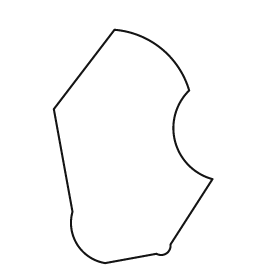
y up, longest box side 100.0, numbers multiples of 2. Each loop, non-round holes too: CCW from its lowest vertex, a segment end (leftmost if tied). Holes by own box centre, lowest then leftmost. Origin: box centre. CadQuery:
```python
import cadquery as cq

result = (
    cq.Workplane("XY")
    .moveTo(-12.0, -50.0)
    .lineTo(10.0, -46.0)
    .threePointArc((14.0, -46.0), (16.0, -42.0))
    .lineTo(34.0, -14.0)
    .threePointArc((18.0, 2.0), (24.0, 24.0))
    .threePointArc((12.0, 42.0), (-8.0, 50.0))
    .lineTo(-34.0, 16.0)
    .lineTo(-26.0, -28.0)
    .threePointArc((-24.0, -42.0), (-12.0, -50.0))
    .close()
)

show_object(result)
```